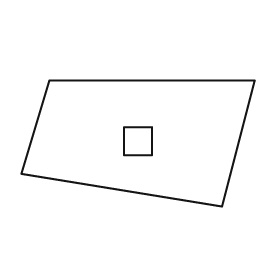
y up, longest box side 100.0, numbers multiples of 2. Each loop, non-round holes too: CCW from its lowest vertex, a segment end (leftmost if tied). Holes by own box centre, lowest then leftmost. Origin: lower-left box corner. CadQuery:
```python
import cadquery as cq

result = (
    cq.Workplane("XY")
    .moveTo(86.0, 0.0)
    .lineTo(100.0, 54.0)
    .lineTo(12.0, 54.0)
    .lineTo(0.0, 14.0)
    .close()
    .moveTo(44.0, 22.0)
    .lineTo(56.0, 22.0)
    .lineTo(56.0, 34.0)
    .lineTo(44.0, 34.0)
    .close()
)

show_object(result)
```